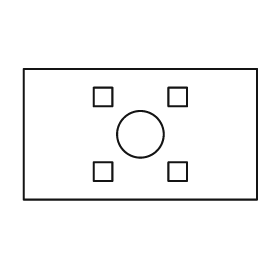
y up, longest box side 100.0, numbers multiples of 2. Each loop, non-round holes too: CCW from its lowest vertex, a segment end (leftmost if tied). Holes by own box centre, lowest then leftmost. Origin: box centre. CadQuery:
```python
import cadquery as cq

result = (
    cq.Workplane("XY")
    .moveTo(-50.0, -28.0)
    .lineTo(50.0, -28.0)
    .lineTo(50.0, 28.0)
    .lineTo(-50.0, 28.0)
    .close()
    .moveTo(-20.0, -20.0)
    .lineTo(-12.0, -20.0)
    .lineTo(-12.0, -12.0)
    .lineTo(-20.0, -12.0)
    .close()
    .moveTo(12.0, -20.0)
    .lineTo(20.0, -20.0)
    .lineTo(20.0, -12.0)
    .lineTo(12.0, -12.0)
    .close()
    .moveTo(0.0, 0.0)
    .circle(10.0)
    .moveTo(-20.0, 12.0)
    .lineTo(-12.0, 12.0)
    .lineTo(-12.0, 20.0)
    .lineTo(-20.0, 20.0)
    .close()
    .moveTo(12.0, 12.0)
    .lineTo(20.0, 12.0)
    .lineTo(20.0, 20.0)
    .lineTo(12.0, 20.0)
    .close()
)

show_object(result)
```